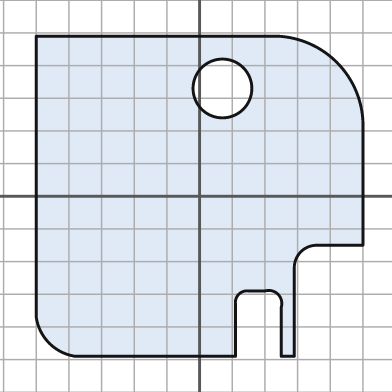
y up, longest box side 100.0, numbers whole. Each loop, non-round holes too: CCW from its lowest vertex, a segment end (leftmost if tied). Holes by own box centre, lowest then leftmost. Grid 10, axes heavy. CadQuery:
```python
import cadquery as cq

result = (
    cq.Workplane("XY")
    .moveTo(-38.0, -49.0)
    .lineTo(11.0, -49.0)
    .lineTo(11.0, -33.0)
    .threePointArc((12.0, -30.0), (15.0, -29.0))
    .lineTo(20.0, -29.0)
    .threePointArc((24.0, -30.0), (25.0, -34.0))
    .lineTo(25.0, -49.0)
    .lineTo(29.0, -49.0)
    .lineTo(29.0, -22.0)
    .threePointArc((31.0, -17.0), (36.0, -15.0))
    .lineTo(50.0, -15.0)
    .lineTo(50.0, 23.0)
    .threePointArc((42.0, 41.0), (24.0, 49.0))
    .lineTo(-50.0, 49.0)
    .lineTo(-50.0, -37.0)
    .threePointArc((-46.0, -45.0), (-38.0, -49.0))
    .close()
    .moveTo(7.0, 33.0)
    .circle(9.0)
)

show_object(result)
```